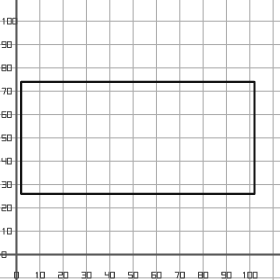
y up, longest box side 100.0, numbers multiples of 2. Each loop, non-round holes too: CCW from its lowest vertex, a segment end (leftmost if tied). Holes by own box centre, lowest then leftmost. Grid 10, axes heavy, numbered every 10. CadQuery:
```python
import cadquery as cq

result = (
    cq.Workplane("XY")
    .moveTo(2.0, 26.0)
    .lineTo(102.0, 26.0)
    .lineTo(102.0, 74.0)
    .lineTo(2.0, 74.0)
    .close()
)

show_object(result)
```